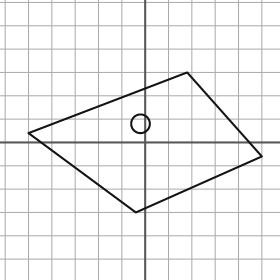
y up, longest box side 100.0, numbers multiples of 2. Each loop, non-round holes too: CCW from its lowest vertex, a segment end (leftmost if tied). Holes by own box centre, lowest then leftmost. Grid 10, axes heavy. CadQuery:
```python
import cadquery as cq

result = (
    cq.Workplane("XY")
    .moveTo(-4.0, -30.0)
    .lineTo(50.0, -6.0)
    .lineTo(18.0, 30.0)
    .lineTo(-50.0, 4.0)
    .close()
    .moveTo(-2.0, 8.0)
    .circle(4.0)
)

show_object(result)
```